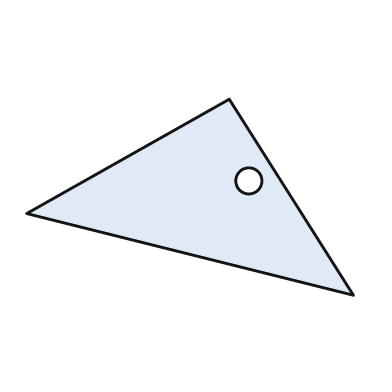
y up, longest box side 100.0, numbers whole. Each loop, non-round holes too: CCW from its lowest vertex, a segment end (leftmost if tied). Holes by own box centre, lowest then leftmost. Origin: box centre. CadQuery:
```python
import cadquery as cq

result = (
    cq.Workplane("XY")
    .moveTo(50.0, -30.0)
    .lineTo(12.0, 30.0)
    .lineTo(-50.0, -5.0)
    .close()
    .moveTo(18.0, 5.0)
    .circle(4.0)
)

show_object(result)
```